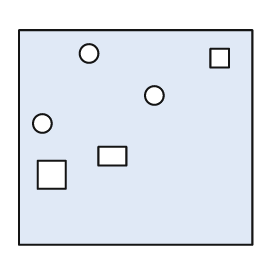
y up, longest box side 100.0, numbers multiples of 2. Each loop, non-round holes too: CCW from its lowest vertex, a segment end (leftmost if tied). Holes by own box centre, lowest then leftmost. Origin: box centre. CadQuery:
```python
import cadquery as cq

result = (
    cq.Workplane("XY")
    .moveTo(-50.0, -46.0)
    .lineTo(50.0, -46.0)
    .lineTo(50.0, 46.0)
    .lineTo(-50.0, 46.0)
    .close()
    .moveTo(-42.0, -22.0)
    .lineTo(-30.0, -22.0)
    .lineTo(-30.0, -10.0)
    .lineTo(-42.0, -10.0)
    .close()
    .moveTo(-16.0, -12.0)
    .lineTo(-4.0, -12.0)
    .lineTo(-4.0, -4.0)
    .lineTo(-16.0, -4.0)
    .close()
    .moveTo(-40.0, 6.0)
    .circle(4.0)
    .moveTo(8.0, 18.0)
    .circle(4.0)
    .moveTo(32.0, 30.0)
    .lineTo(40.0, 30.0)
    .lineTo(40.0, 38.0)
    .lineTo(32.0, 38.0)
    .close()
    .moveTo(-20.0, 36.0)
    .circle(4.0)
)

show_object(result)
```